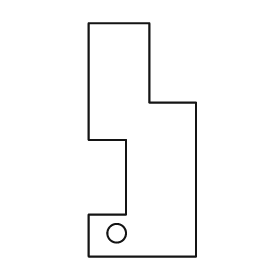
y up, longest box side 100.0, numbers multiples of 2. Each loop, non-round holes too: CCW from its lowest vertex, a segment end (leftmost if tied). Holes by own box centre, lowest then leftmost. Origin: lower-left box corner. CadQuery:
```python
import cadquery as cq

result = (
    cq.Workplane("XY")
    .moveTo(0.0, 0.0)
    .lineTo(46.0, 0.0)
    .lineTo(46.0, 66.0)
    .lineTo(26.0, 66.0)
    .lineTo(26.0, 100.0)
    .lineTo(0.0, 100.0)
    .lineTo(0.0, 50.0)
    .lineTo(16.0, 50.0)
    .lineTo(16.0, 18.0)
    .lineTo(0.0, 18.0)
    .close()
    .moveTo(12.0, 10.0)
    .circle(4.0)
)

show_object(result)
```